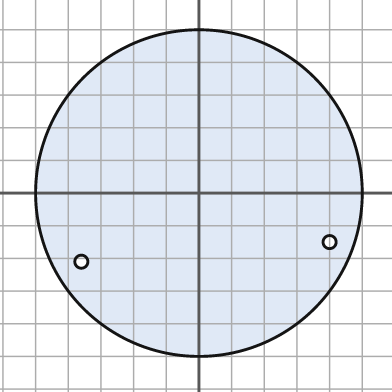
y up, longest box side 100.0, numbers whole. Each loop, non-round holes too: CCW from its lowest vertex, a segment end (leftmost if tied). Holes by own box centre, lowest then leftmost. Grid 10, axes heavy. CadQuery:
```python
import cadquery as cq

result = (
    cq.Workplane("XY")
    .moveTo(0.0, 0.0)
    .circle(50.0)
    .moveTo(-36.0, -21.0)
    .circle(2.0)
    .moveTo(40.0, -15.0)
    .circle(2.0)
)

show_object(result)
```